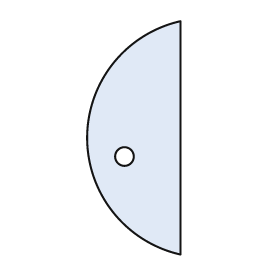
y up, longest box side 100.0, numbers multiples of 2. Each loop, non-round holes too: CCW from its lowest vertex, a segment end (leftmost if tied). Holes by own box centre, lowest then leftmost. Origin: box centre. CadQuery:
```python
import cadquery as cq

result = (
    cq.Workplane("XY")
    .moveTo(20.0, -50.0)
    .lineTo(20.0, 50.0)
    .threePointArc((-20.0, 0.0), (20.0, -50.0))
    .close()
    .moveTo(-4.0, -8.0)
    .circle(4.0)
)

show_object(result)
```